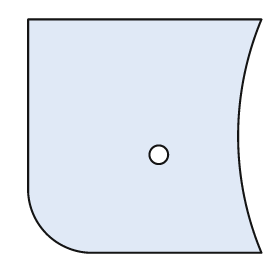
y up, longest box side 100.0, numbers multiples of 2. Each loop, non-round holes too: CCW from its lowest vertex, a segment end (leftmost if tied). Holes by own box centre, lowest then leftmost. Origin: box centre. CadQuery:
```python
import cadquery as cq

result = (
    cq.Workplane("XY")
    .moveTo(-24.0, -50.0)
    .lineTo(50.0, -50.0)
    .threePointArc((40.0, 0.0), (50.0, 50.0))
    .lineTo(-50.0, 50.0)
    .lineTo(-50.0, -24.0)
    .threePointArc((-42.0, -42.0), (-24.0, -50.0))
    .close()
    .moveTo(6.0, -8.0)
    .circle(4.0)
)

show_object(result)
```